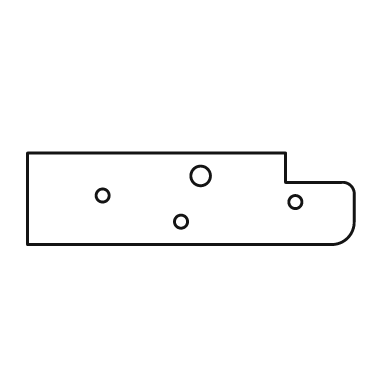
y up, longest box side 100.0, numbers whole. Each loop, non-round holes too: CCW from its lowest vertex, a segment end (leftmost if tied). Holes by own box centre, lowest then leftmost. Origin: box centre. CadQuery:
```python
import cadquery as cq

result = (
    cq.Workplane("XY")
    .moveTo(-50.0, -14.0)
    .lineTo(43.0, -14.0)
    .threePointArc((48.0, -12.0), (50.0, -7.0))
    .lineTo(50.0, 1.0)
    .threePointArc((49.0, 4.0), (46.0, 5.0))
    .lineTo(29.0, 5.0)
    .lineTo(29.0, 14.0)
    .lineTo(-50.0, 14.0)
    .close()
    .moveTo(-3.0, -7.0)
    .circle(2.0)
    .moveTo(32.0, -1.0)
    .circle(2.0)
    .moveTo(-27.0, 1.0)
    .circle(2.0)
    .moveTo(3.0, 7.0)
    .circle(3.0)
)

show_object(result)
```